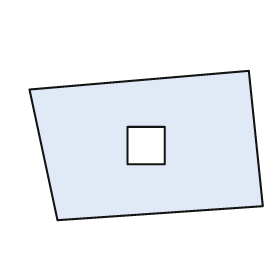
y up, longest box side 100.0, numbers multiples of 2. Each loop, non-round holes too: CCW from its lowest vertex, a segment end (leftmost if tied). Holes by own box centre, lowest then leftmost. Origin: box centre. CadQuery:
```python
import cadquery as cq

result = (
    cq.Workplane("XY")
    .moveTo(-38.0, -32.0)
    .lineTo(50.0, -26.0)
    .lineTo(44.0, 32.0)
    .lineTo(-50.0, 24.0)
    .close()
    .moveTo(-8.0, -8.0)
    .lineTo(8.0, -8.0)
    .lineTo(8.0, 8.0)
    .lineTo(-8.0, 8.0)
    .close()
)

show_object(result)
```